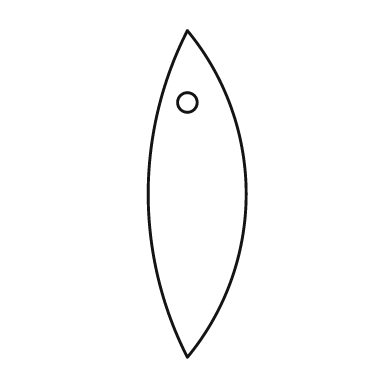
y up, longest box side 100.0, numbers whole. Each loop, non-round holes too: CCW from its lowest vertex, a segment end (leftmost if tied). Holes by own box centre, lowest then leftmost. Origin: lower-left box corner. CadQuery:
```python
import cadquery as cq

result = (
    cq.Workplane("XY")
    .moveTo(12.0, 0.0)
    .threePointArc((30.0, 50.0), (12.0, 100.0))
    .threePointArc((0.0, 50.0), (12.0, 0.0))
    .close()
    .moveTo(12.0, 78.0)
    .circle(3.0)
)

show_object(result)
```